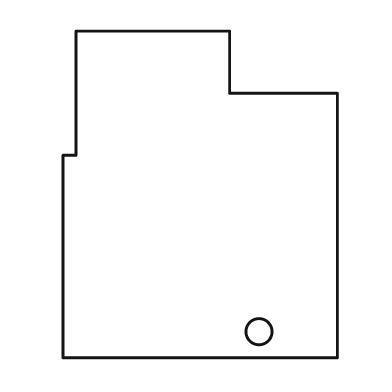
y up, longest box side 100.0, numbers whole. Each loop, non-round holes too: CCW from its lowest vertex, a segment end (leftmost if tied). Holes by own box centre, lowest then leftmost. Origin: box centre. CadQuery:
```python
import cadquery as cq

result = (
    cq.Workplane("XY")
    .moveTo(-42.0, -50.0)
    .lineTo(42.0, -50.0)
    .lineTo(42.0, 31.0)
    .lineTo(9.0, 31.0)
    .lineTo(9.0, 50.0)
    .lineTo(-38.0, 50.0)
    .lineTo(-38.0, 12.0)
    .lineTo(-42.0, 12.0)
    .close()
    .moveTo(18.0, -42.0)
    .circle(4.0)
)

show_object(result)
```